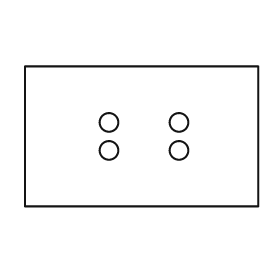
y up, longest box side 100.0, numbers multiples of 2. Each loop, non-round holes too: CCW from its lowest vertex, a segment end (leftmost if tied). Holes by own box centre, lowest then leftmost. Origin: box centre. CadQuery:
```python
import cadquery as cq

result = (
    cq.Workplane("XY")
    .moveTo(-50.0, -30.0)
    .lineTo(50.0, -30.0)
    .lineTo(50.0, 30.0)
    .lineTo(-50.0, 30.0)
    .close()
    .moveTo(-14.0, -6.0)
    .circle(4.0)
    .moveTo(16.0, -6.0)
    .circle(4.0)
    .moveTo(-14.0, 6.0)
    .circle(4.0)
    .moveTo(16.0, 6.0)
    .circle(4.0)
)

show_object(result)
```